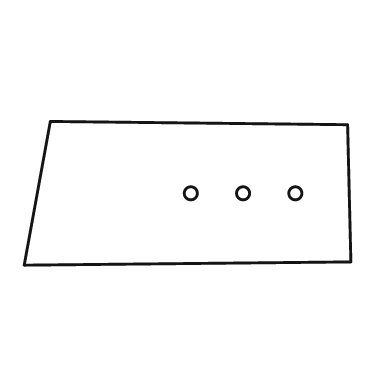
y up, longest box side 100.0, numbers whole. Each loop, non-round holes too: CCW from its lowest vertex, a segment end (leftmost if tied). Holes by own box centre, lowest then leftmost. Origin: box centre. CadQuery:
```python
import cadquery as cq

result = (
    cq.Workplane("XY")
    .moveTo(-50.0, -22.0)
    .lineTo(50.0, -21.0)
    .lineTo(49.0, 21.0)
    .lineTo(-42.0, 22.0)
    .close()
    .moveTo(1.0, 0.0)
    .circle(2.0)
    .moveTo(17.0, 0.0)
    .circle(2.0)
    .moveTo(33.0, 0.0)
    .circle(2.0)
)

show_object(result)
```